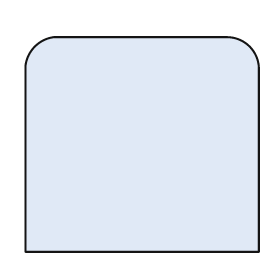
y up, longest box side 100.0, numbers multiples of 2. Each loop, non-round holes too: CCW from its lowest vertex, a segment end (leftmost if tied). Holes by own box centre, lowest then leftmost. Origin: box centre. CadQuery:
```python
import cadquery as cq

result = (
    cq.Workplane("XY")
    .moveTo(-50.0, -46.0)
    .lineTo(50.0, -46.0)
    .lineTo(50.0, 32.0)
    .threePointArc((46.0, 42.0), (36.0, 46.0))
    .lineTo(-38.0, 46.0)
    .threePointArc((-46.0, 42.0), (-50.0, 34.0))
    .close()
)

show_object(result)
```